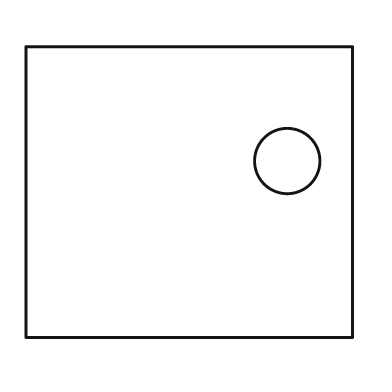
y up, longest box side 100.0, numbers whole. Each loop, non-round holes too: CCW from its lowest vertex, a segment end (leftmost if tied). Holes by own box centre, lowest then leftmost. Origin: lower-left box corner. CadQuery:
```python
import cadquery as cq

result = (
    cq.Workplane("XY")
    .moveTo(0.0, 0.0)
    .lineTo(100.0, 0.0)
    .lineTo(100.0, 89.0)
    .lineTo(0.0, 89.0)
    .close()
    .moveTo(80.0, 54.0)
    .circle(10.0)
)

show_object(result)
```